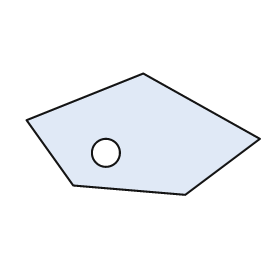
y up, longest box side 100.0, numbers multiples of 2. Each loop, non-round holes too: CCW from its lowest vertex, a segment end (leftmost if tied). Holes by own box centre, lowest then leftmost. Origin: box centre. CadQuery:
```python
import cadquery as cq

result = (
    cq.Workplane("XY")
    .moveTo(18.0, -26.0)
    .lineTo(50.0, -2.0)
    .lineTo(0.0, 26.0)
    .lineTo(-50.0, 6.0)
    .lineTo(-30.0, -22.0)
    .close()
    .moveTo(-16.0, -8.0)
    .circle(6.0)
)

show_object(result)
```